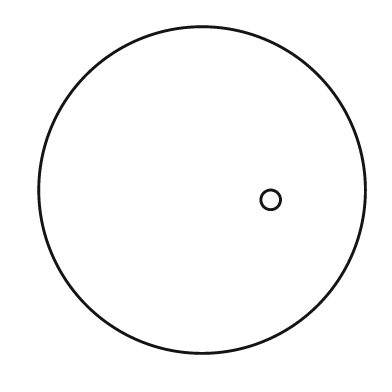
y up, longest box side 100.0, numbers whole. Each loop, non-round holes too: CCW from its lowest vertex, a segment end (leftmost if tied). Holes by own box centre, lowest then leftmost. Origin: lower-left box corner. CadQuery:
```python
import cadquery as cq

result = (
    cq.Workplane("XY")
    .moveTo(50.0, 50.0)
    .circle(50.0)
    .moveTo(71.0, 47.0)
    .circle(3.0)
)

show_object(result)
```